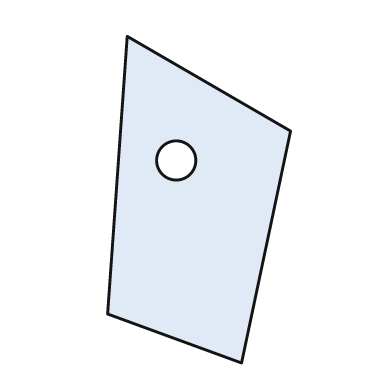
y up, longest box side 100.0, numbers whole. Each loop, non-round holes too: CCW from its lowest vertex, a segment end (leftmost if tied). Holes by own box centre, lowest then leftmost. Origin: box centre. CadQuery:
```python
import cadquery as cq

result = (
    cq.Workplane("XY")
    .moveTo(13.0, -50.0)
    .lineTo(28.0, 21.0)
    .lineTo(-22.0, 50.0)
    .lineTo(-28.0, -35.0)
    .close()
    .moveTo(-7.0, 12.0)
    .circle(6.0)
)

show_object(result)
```